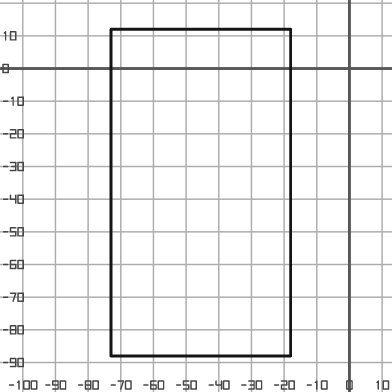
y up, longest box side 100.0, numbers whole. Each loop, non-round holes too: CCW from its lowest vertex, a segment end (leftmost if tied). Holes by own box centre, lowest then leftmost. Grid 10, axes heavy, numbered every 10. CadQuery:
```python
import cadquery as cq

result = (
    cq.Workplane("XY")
    .moveTo(-73.0, -88.0)
    .lineTo(-18.0, -88.0)
    .lineTo(-18.0, 12.0)
    .lineTo(-73.0, 12.0)
    .close()
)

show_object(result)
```